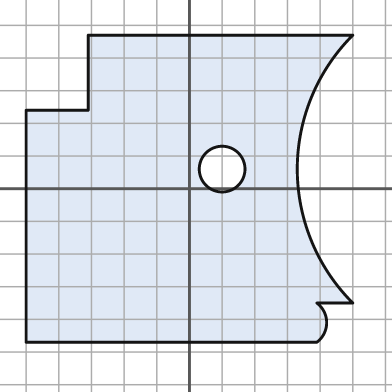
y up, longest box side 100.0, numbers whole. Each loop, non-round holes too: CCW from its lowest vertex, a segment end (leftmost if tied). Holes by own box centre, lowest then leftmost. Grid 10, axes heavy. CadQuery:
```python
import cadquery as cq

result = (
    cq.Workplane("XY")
    .moveTo(-50.0, -47.0)
    .lineTo(39.0, -47.0)
    .threePointArc((42.0, -41.0), (39.0, -35.0))
    .lineTo(50.0, -35.0)
    .threePointArc((33.0, 6.0), (50.0, 47.0))
    .lineTo(-31.0, 47.0)
    .lineTo(-31.0, 24.0)
    .lineTo(-50.0, 24.0)
    .close()
    .moveTo(10.0, 6.0)
    .circle(7.0)
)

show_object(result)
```